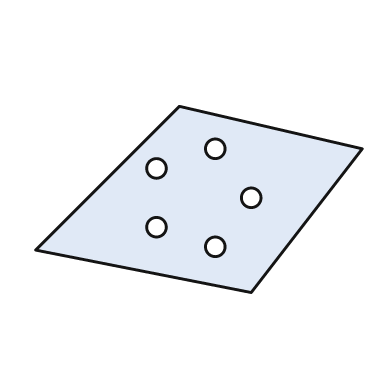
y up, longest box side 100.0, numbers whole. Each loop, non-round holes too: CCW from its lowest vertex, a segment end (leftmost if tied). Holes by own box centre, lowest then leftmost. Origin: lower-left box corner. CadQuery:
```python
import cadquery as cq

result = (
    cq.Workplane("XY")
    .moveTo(66.0, 0.0)
    .lineTo(100.0, 44.0)
    .lineTo(44.0, 57.0)
    .lineTo(0.0, 13.0)
    .close()
    .moveTo(55.0, 14.0)
    .circle(3.0)
    .moveTo(37.0, 20.0)
    .circle(3.0)
    .moveTo(66.0, 29.0)
    .circle(3.0)
    .moveTo(37.0, 38.0)
    .circle(3.0)
    .moveTo(55.0, 44.0)
    .circle(3.0)
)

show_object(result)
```